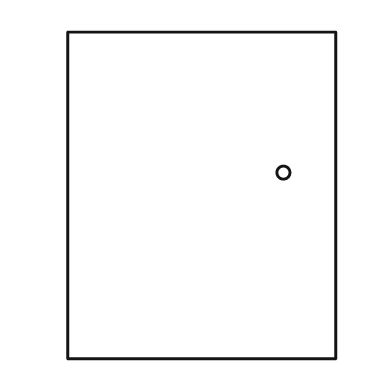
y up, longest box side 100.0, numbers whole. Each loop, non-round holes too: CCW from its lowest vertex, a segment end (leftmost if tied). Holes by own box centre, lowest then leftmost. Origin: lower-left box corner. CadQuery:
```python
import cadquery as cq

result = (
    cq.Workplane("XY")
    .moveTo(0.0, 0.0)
    .lineTo(82.0, 0.0)
    .lineTo(82.0, 100.0)
    .lineTo(0.0, 100.0)
    .close()
    .moveTo(66.0, 57.0)
    .circle(2.0)
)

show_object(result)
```